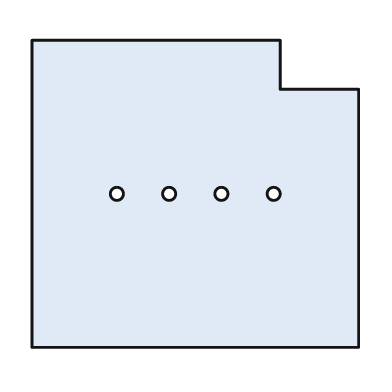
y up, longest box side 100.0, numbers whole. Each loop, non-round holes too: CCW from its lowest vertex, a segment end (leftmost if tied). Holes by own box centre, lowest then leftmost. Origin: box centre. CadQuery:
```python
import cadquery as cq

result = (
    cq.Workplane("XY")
    .moveTo(-50.0, -47.0)
    .lineTo(50.0, -47.0)
    .lineTo(50.0, 32.0)
    .lineTo(26.0, 32.0)
    .lineTo(26.0, 47.0)
    .lineTo(-50.0, 47.0)
    .close()
    .moveTo(-24.0, 0.0)
    .circle(2.0)
    .moveTo(-8.0, 0.0)
    .circle(2.0)
    .moveTo(8.0, 0.0)
    .circle(2.0)
    .moveTo(24.0, 0.0)
    .circle(2.0)
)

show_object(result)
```